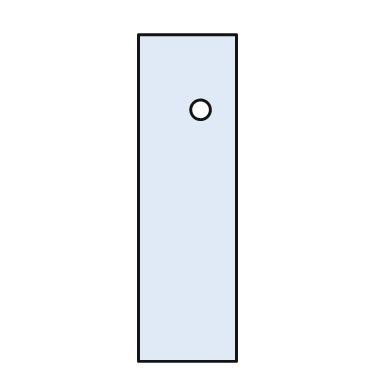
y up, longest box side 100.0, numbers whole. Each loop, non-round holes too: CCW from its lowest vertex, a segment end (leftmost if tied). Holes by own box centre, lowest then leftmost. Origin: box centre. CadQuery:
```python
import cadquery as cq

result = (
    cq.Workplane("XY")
    .moveTo(-15.0, -50.0)
    .lineTo(15.0, -50.0)
    .lineTo(15.0, 50.0)
    .lineTo(-15.0, 50.0)
    .close()
    .moveTo(4.0, 27.0)
    .circle(3.0)
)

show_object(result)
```